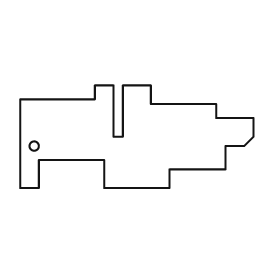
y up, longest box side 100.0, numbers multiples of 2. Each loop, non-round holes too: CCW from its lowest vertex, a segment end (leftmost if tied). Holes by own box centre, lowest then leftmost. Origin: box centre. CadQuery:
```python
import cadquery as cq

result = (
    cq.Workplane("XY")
    .moveTo(-50.0, -22.0)
    .lineTo(-42.0, -22.0)
    .lineTo(-42.0, -10.0)
    .lineTo(-14.0, -10.0)
    .lineTo(-14.0, -22.0)
    .lineTo(14.0, -22.0)
    .lineTo(14.0, -14.0)
    .lineTo(38.0, -14.0)
    .lineTo(38.0, -4.0)
    .lineTo(46.0, -4.0)
    .lineTo(50.0, 0.0)
    .lineTo(50.0, 8.0)
    .lineTo(34.0, 8.0)
    .lineTo(34.0, 14.0)
    .lineTo(6.0, 14.0)
    .lineTo(6.0, 22.0)
    .lineTo(-6.0, 22.0)
    .lineTo(-6.0, 0.0)
    .lineTo(-10.0, 0.0)
    .lineTo(-10.0, 22.0)
    .lineTo(-18.0, 22.0)
    .lineTo(-18.0, 16.0)
    .lineTo(-50.0, 16.0)
    .close()
    .moveTo(-44.0, -4.0)
    .circle(2.0)
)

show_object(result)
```